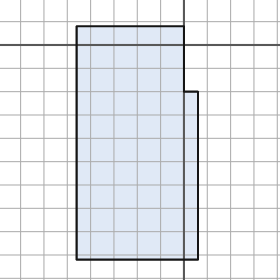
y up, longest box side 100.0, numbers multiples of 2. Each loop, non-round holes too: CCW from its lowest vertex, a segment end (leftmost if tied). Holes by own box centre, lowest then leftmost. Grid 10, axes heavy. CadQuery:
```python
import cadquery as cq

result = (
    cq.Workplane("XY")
    .moveTo(-46.0, -92.0)
    .lineTo(6.0, -92.0)
    .lineTo(6.0, -20.0)
    .lineTo(0.0, -20.0)
    .lineTo(0.0, 8.0)
    .lineTo(-46.0, 8.0)
    .close()
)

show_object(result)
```